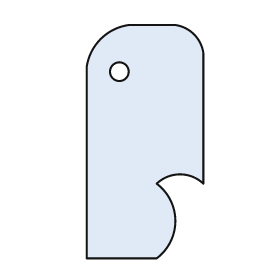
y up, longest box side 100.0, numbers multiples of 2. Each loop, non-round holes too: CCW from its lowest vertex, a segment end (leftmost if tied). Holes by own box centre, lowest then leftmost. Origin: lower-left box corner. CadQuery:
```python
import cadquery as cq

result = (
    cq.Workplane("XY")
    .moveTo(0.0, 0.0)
    .lineTo(30.0, 0.0)
    .threePointArc((38.0, 16.0), (30.0, 32.0))
    .threePointArc((40.0, 36.0), (50.0, 32.0))
    .lineTo(50.0, 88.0)
    .threePointArc((46.0, 96.0), (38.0, 100.0))
    .lineTo(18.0, 100.0)
    .threePointArc((6.0, 94.0), (0.0, 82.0))
    .close()
    .moveTo(14.0, 80.0)
    .circle(4.0)
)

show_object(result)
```